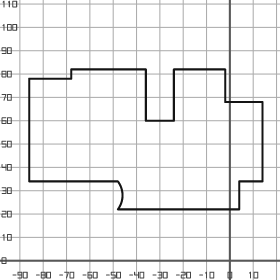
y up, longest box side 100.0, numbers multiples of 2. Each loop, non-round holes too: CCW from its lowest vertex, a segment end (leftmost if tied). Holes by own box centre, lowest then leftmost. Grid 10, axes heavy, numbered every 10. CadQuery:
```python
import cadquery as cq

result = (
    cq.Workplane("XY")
    .moveTo(-48.0, 22.0)
    .lineTo(4.0, 22.0)
    .lineTo(4.0, 34.0)
    .lineTo(14.0, 34.0)
    .lineTo(14.0, 68.0)
    .lineTo(-2.0, 68.0)
    .lineTo(-2.0, 82.0)
    .lineTo(-24.0, 82.0)
    .lineTo(-24.0, 60.0)
    .lineTo(-36.0, 60.0)
    .lineTo(-36.0, 82.0)
    .lineTo(-68.0, 82.0)
    .lineTo(-68.0, 78.0)
    .lineTo(-86.0, 78.0)
    .lineTo(-86.0, 34.0)
    .lineTo(-48.0, 34.0)
    .threePointArc((-46.0, 28.0), (-48.0, 22.0))
    .close()
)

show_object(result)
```